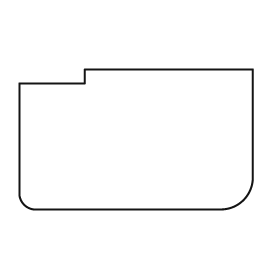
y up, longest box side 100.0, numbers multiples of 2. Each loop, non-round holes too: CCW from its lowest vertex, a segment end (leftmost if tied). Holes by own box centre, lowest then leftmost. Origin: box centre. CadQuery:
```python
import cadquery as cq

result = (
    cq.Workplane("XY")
    .moveTo(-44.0, -30.0)
    .lineTo(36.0, -30.0)
    .threePointArc((46.0, -26.0), (50.0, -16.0))
    .lineTo(50.0, 30.0)
    .lineTo(-22.0, 30.0)
    .lineTo(-22.0, 24.0)
    .lineTo(-50.0, 24.0)
    .lineTo(-50.0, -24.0)
    .threePointArc((-48.0, -28.0), (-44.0, -30.0))
    .close()
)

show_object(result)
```